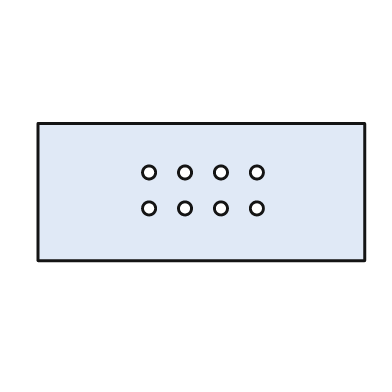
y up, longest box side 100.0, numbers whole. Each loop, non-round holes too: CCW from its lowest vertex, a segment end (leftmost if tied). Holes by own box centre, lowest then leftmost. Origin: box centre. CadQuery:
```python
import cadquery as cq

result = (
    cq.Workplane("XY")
    .moveTo(-50.0, -21.0)
    .lineTo(50.0, -21.0)
    .lineTo(50.0, 21.0)
    .lineTo(-50.0, 21.0)
    .close()
    .moveTo(-16.0, -5.0)
    .circle(2.0)
    .moveTo(-5.0, -5.0)
    .circle(2.0)
    .moveTo(6.0, -5.0)
    .circle(2.0)
    .moveTo(17.0, -5.0)
    .circle(2.0)
    .moveTo(-16.0, 6.0)
    .circle(2.0)
    .moveTo(-5.0, 6.0)
    .circle(2.0)
    .moveTo(6.0, 6.0)
    .circle(2.0)
    .moveTo(17.0, 6.0)
    .circle(2.0)
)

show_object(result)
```